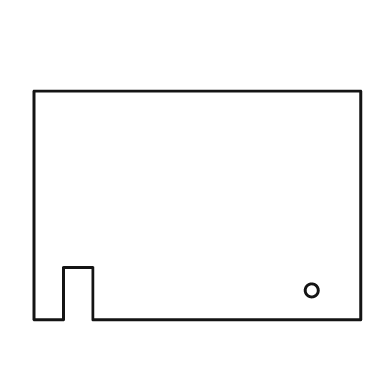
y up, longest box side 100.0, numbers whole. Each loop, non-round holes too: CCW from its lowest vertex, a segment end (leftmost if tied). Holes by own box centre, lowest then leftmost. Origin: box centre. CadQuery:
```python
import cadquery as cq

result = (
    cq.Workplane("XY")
    .moveTo(-50.0, -35.0)
    .lineTo(-41.0, -35.0)
    .lineTo(-41.0, -19.0)
    .lineTo(-32.0, -19.0)
    .lineTo(-32.0, -35.0)
    .lineTo(50.0, -35.0)
    .lineTo(50.0, 35.0)
    .lineTo(-50.0, 35.0)
    .close()
    .moveTo(35.0, -26.0)
    .circle(2.0)
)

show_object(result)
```